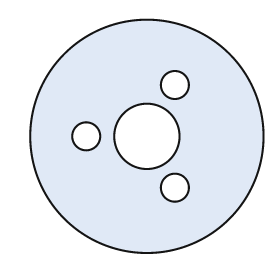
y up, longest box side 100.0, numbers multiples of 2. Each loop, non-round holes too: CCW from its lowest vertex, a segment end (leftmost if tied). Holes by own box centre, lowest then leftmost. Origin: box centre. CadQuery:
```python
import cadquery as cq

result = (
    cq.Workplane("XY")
    .moveTo(0.0, 0.0)
    .circle(50.0)
    .moveTo(12.0, -22.0)
    .circle(6.0)
    .moveTo(-26.0, 0.0)
    .circle(6.0)
    .moveTo(0.0, 0.0)
    .circle(14.0)
    .moveTo(12.0, 22.0)
    .circle(6.0)
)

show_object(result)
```